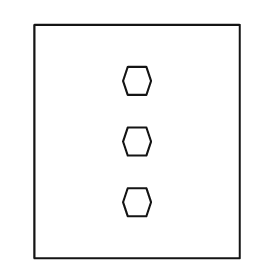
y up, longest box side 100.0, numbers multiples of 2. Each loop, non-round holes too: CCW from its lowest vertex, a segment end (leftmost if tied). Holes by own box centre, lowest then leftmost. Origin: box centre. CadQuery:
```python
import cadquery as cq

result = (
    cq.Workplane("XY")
    .moveTo(-44.0, -50.0)
    .lineTo(44.0, -50.0)
    .lineTo(44.0, 50.0)
    .lineTo(-44.0, 50.0)
    .close()
    .moveTo(-4.0, -32.0)
    .lineTo(4.0, -32.0)
    .lineTo(6.0, -26.0)
    .lineTo(4.0, -20.0)
    .lineTo(-4.0, -20.0)
    .lineTo(-6.0, -26.0)
    .close()
    .moveTo(-4.0, -6.0)
    .lineTo(4.0, -6.0)
    .lineTo(6.0, 0.0)
    .lineTo(4.0, 6.0)
    .lineTo(-4.0, 6.0)
    .lineTo(-6.0, 0.0)
    .close()
    .moveTo(-4.0, 20.0)
    .lineTo(4.0, 20.0)
    .lineTo(6.0, 26.0)
    .lineTo(4.0, 32.0)
    .lineTo(-4.0, 32.0)
    .lineTo(-6.0, 26.0)
    .close()
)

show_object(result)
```